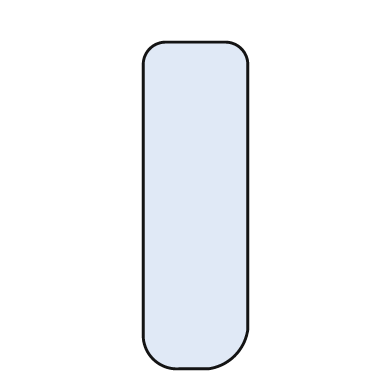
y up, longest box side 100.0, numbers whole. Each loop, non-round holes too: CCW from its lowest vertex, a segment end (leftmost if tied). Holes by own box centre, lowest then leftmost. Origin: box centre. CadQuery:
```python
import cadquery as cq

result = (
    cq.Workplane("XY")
    .moveTo(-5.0, -50.0)
    .lineTo(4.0, -50.0)
    .threePointArc((12.0, -46.0), (16.0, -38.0))
    .lineTo(16.0, 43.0)
    .threePointArc((14.0, 48.0), (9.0, 50.0))
    .lineTo(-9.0, 50.0)
    .threePointArc((-14.0, 48.0), (-16.0, 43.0))
    .lineTo(-16.0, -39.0)
    .threePointArc((-13.0, -47.0), (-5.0, -50.0))
    .close()
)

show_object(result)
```